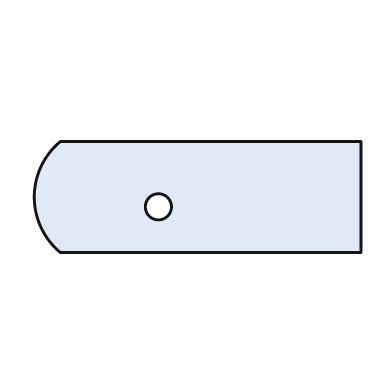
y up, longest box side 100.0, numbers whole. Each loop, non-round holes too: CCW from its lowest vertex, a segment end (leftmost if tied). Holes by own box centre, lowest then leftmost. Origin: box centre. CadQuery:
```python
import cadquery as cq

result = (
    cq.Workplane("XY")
    .moveTo(-42.0, -17.0)
    .lineTo(50.0, -17.0)
    .lineTo(50.0, 17.0)
    .lineTo(-42.0, 17.0)
    .threePointArc((-50.0, 0.0), (-42.0, -17.0))
    .close()
    .moveTo(-12.0, -3.0)
    .circle(4.0)
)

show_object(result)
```